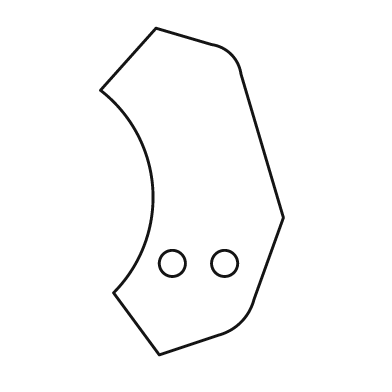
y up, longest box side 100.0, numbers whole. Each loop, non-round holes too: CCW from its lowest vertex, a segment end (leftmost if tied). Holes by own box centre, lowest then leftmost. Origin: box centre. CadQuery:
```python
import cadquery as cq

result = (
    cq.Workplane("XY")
    .moveTo(-10.0, -50.0)
    .lineTo(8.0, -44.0)
    .threePointArc((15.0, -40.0), (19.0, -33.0))
    .lineTo(28.0, -8.0)
    .lineTo(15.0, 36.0)
    .threePointArc((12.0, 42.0), (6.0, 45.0))
    .lineTo(-11.0, 50.0)
    .lineTo(-28.0, 31.0)
    .threePointArc((-12.0, 1.0), (-24.0, -31.0))
    .close()
    .moveTo(-6.0, -22.0)
    .circle(4.0)
    .moveTo(10.0, -22.0)
    .circle(4.0)
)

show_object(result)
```